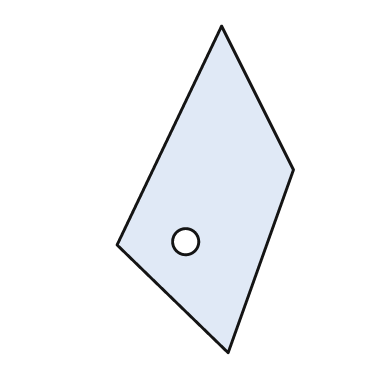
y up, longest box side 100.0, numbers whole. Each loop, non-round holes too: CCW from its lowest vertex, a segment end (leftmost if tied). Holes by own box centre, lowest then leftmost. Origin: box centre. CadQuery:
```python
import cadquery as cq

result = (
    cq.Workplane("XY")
    .moveTo(7.0, -50.0)
    .lineTo(27.0, 6.0)
    .lineTo(5.0, 50.0)
    .lineTo(-27.0, -17.0)
    .close()
    .moveTo(-6.0, -16.0)
    .circle(4.0)
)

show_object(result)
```